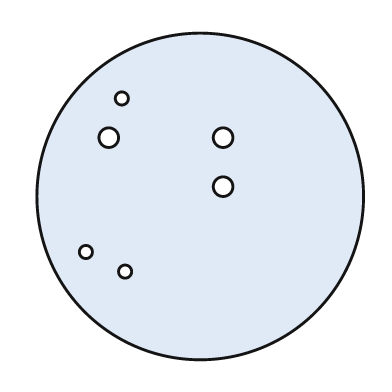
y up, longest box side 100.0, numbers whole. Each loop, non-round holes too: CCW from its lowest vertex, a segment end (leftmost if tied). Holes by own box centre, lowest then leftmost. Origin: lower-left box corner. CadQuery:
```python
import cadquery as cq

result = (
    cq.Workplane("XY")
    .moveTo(50.0, 50.0)
    .circle(50.0)
    .moveTo(27.0, 27.0)
    .circle(2.0)
    .moveTo(15.0, 33.0)
    .circle(2.0)
    .moveTo(57.0, 53.0)
    .circle(3.0)
    .moveTo(22.0, 68.0)
    .circle(3.0)
    .moveTo(57.0, 68.0)
    .circle(3.0)
    .moveTo(26.0, 80.0)
    .circle(2.0)
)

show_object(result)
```